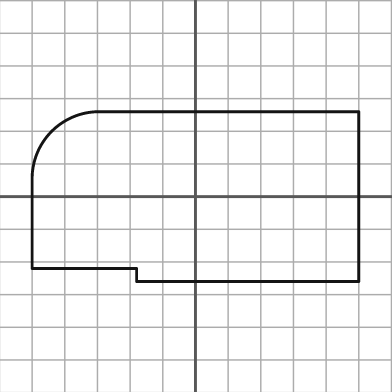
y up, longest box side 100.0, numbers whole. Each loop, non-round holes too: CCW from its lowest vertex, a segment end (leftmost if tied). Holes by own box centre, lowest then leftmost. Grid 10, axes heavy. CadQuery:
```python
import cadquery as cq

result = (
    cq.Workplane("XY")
    .moveTo(-18.0, -26.0)
    .lineTo(50.0, -26.0)
    .lineTo(50.0, 26.0)
    .lineTo(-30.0, 26.0)
    .threePointArc((-44.0, 20.0), (-50.0, 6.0))
    .lineTo(-50.0, -22.0)
    .lineTo(-18.0, -22.0)
    .close()
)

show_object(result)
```